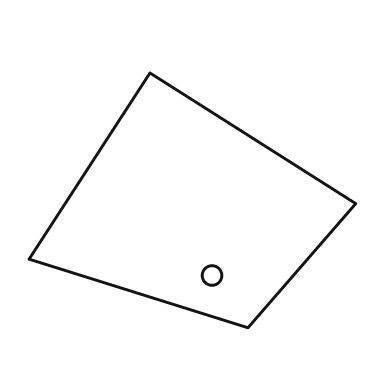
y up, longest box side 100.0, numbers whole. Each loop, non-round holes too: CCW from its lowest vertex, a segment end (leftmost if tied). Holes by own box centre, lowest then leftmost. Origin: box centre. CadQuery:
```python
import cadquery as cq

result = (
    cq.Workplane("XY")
    .moveTo(17.0, -39.0)
    .lineTo(50.0, -1.0)
    .lineTo(-13.0, 39.0)
    .lineTo(-50.0, -18.0)
    .close()
    .moveTo(6.0, -23.0)
    .circle(3.0)
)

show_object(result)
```